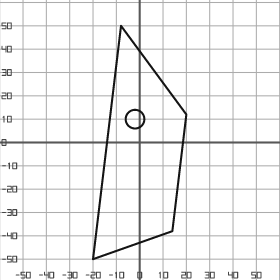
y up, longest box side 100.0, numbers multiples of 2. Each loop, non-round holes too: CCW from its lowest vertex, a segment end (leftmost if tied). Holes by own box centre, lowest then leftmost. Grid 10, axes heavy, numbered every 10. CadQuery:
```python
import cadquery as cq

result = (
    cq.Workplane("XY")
    .moveTo(-20.0, -50.0)
    .lineTo(14.0, -38.0)
    .lineTo(20.0, 12.0)
    .lineTo(-8.0, 50.0)
    .close()
    .moveTo(-2.0, 10.0)
    .circle(4.0)
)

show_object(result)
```